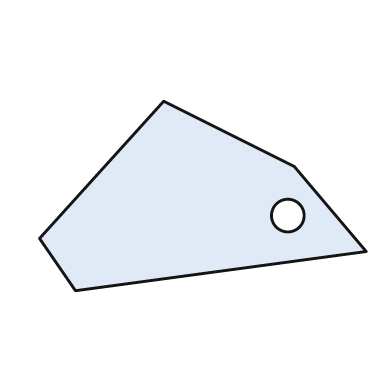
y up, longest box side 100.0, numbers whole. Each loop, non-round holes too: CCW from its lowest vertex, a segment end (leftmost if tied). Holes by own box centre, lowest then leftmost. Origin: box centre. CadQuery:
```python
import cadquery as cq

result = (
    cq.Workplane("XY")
    .moveTo(-39.0, -29.0)
    .lineTo(50.0, -17.0)
    .lineTo(28.0, 9.0)
    .lineTo(-12.0, 29.0)
    .lineTo(-50.0, -13.0)
    .close()
    .moveTo(26.0, -6.0)
    .circle(5.0)
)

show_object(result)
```